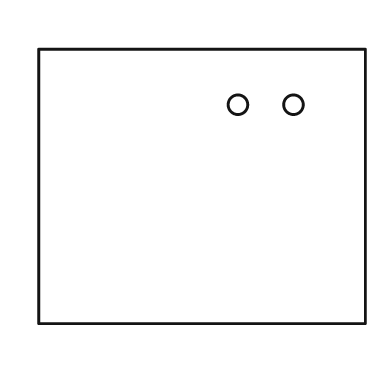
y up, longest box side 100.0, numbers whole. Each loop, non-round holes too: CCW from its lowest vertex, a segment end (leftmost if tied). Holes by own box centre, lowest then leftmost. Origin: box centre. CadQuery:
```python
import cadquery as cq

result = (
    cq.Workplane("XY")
    .moveTo(-50.0, -42.0)
    .lineTo(50.0, -42.0)
    .lineTo(50.0, 42.0)
    .lineTo(-50.0, 42.0)
    .close()
    .moveTo(11.0, 25.0)
    .circle(3.0)
    .moveTo(28.0, 25.0)
    .circle(3.0)
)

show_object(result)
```